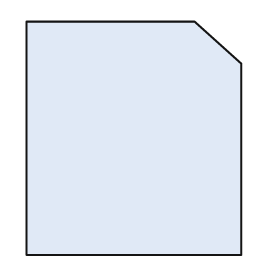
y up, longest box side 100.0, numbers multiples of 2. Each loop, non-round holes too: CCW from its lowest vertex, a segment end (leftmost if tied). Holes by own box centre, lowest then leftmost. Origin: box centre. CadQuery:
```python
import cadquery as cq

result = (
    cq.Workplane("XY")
    .moveTo(-46.0, -50.0)
    .lineTo(46.0, -50.0)
    .lineTo(46.0, 32.0)
    .lineTo(26.0, 50.0)
    .lineTo(-46.0, 50.0)
    .close()
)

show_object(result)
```